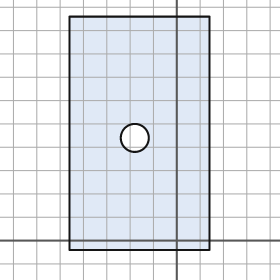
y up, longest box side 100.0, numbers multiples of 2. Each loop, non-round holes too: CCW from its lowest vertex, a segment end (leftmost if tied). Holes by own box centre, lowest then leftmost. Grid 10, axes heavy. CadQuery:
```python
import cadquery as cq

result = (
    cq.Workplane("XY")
    .moveTo(-46.0, -4.0)
    .lineTo(14.0, -4.0)
    .lineTo(14.0, 96.0)
    .lineTo(-46.0, 96.0)
    .close()
    .moveTo(-18.0, 44.0)
    .circle(6.0)
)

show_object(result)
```